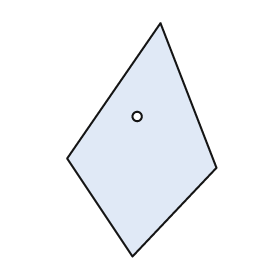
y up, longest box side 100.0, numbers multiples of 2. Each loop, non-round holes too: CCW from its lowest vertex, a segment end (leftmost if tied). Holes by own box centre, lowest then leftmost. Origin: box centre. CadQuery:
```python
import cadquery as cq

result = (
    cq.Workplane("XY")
    .moveTo(-4.0, -50.0)
    .lineTo(32.0, -12.0)
    .lineTo(8.0, 50.0)
    .lineTo(-32.0, -8.0)
    .close()
    .moveTo(-2.0, 10.0)
    .circle(2.0)
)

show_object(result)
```